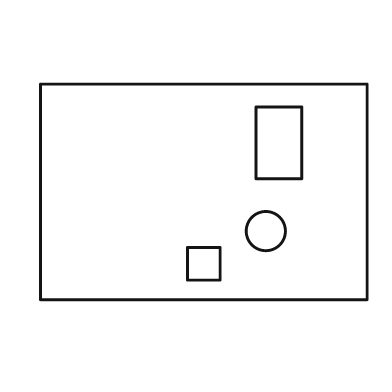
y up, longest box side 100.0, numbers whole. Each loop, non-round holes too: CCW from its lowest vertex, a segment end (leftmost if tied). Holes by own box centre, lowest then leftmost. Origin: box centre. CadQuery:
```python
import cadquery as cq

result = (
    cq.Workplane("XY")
    .moveTo(-50.0, -33.0)
    .lineTo(50.0, -33.0)
    .lineTo(50.0, 33.0)
    .lineTo(-50.0, 33.0)
    .close()
    .moveTo(-5.0, -27.0)
    .lineTo(5.0, -27.0)
    .lineTo(5.0, -17.0)
    .lineTo(-5.0, -17.0)
    .close()
    .moveTo(19.0, -12.0)
    .circle(6.0)
    .moveTo(16.0, 4.0)
    .lineTo(30.0, 4.0)
    .lineTo(30.0, 26.0)
    .lineTo(16.0, 26.0)
    .close()
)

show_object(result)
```